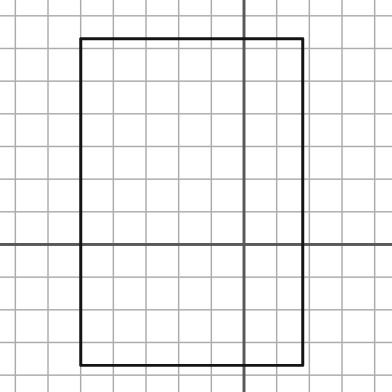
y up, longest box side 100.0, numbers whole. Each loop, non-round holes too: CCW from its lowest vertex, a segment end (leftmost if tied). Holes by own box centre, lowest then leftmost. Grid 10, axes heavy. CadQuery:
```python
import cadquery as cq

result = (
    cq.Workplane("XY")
    .moveTo(-50.0, -37.0)
    .lineTo(18.0, -37.0)
    .lineTo(18.0, 63.0)
    .lineTo(-50.0, 63.0)
    .close()
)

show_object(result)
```